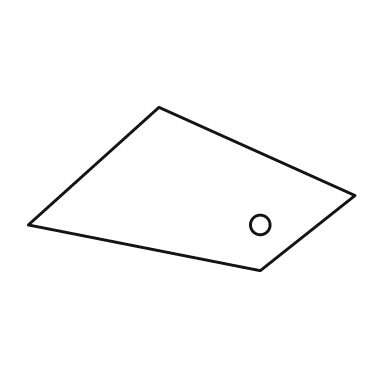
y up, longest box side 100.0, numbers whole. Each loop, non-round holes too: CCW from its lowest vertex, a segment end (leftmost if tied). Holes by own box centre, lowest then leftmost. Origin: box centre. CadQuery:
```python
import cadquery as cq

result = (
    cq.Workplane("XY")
    .moveTo(21.0, -25.0)
    .lineTo(50.0, -2.0)
    .lineTo(-10.0, 25.0)
    .lineTo(-50.0, -11.0)
    .close()
    .moveTo(21.0, -11.0)
    .circle(3.0)
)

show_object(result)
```